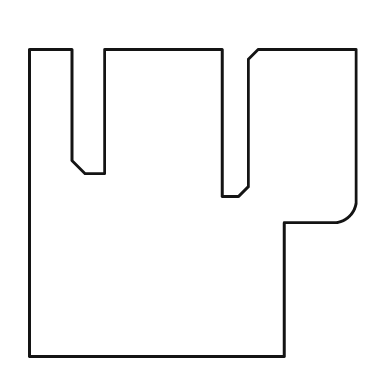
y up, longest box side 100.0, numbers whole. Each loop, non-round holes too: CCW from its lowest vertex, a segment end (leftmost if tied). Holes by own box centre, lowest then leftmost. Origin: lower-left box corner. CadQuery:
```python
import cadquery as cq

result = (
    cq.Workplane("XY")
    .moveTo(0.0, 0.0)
    .lineTo(78.0, 0.0)
    .lineTo(78.0, 41.0)
    .lineTo(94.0, 41.0)
    .threePointArc((98.0, 43.0), (100.0, 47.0))
    .lineTo(100.0, 94.0)
    .lineTo(70.0, 94.0)
    .lineTo(67.0, 91.0)
    .lineTo(67.0, 52.0)
    .lineTo(64.0, 49.0)
    .lineTo(59.0, 49.0)
    .lineTo(59.0, 94.0)
    .lineTo(23.0, 94.0)
    .lineTo(23.0, 56.0)
    .lineTo(17.0, 56.0)
    .lineTo(13.0, 60.0)
    .lineTo(13.0, 94.0)
    .lineTo(0.0, 94.0)
    .close()
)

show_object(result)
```